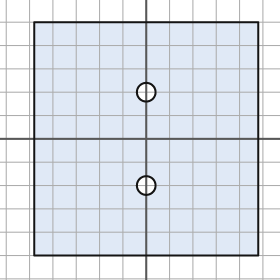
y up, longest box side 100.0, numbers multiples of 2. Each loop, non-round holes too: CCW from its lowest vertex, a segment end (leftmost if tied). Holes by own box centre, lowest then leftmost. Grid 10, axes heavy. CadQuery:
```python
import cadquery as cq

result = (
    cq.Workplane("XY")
    .moveTo(-48.0, -50.0)
    .lineTo(48.0, -50.0)
    .lineTo(48.0, 50.0)
    .lineTo(-48.0, 50.0)
    .close()
    .moveTo(0.0, -20.0)
    .circle(4.0)
    .moveTo(0.0, 20.0)
    .circle(4.0)
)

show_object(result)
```